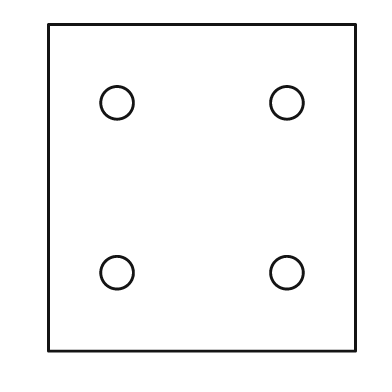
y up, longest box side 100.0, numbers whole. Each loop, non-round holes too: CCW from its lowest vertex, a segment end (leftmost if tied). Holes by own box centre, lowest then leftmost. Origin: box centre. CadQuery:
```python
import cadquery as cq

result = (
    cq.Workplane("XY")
    .moveTo(-47.0, -50.0)
    .lineTo(47.0, -50.0)
    .lineTo(47.0, 50.0)
    .lineTo(-47.0, 50.0)
    .close()
    .moveTo(-26.0, -26.0)
    .circle(5.0)
    .moveTo(26.0, -26.0)
    .circle(5.0)
    .moveTo(-26.0, 26.0)
    .circle(5.0)
    .moveTo(26.0, 26.0)
    .circle(5.0)
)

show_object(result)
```